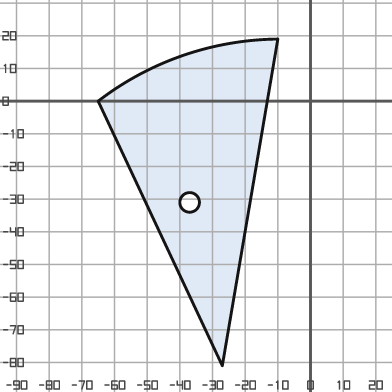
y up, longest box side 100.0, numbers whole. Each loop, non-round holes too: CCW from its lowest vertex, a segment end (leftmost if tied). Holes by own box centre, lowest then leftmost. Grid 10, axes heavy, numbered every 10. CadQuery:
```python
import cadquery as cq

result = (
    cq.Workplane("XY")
    .moveTo(-27.0, -81.0)
    .lineTo(-10.0, 19.0)
    .threePointArc((-39.0, 14.0), (-65.0, 0.0))
    .close()
    .moveTo(-37.0, -31.0)
    .circle(3.0)
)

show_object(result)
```